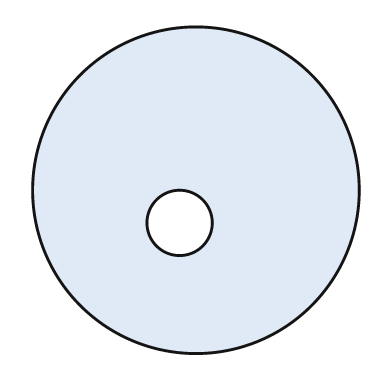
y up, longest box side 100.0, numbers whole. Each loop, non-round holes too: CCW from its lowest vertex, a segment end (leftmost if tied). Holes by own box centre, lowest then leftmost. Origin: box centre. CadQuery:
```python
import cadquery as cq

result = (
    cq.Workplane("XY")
    .moveTo(0.0, 0.0)
    .circle(50.0)
    .moveTo(-5.0, -10.0)
    .circle(10.0)
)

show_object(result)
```